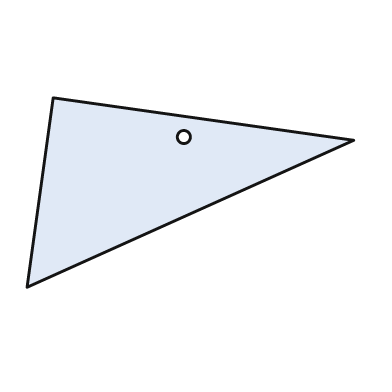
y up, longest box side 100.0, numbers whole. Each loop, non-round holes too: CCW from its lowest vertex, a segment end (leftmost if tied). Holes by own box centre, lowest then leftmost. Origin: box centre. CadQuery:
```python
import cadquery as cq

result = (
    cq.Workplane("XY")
    .moveTo(-50.0, -29.0)
    .lineTo(50.0, 16.0)
    .lineTo(-42.0, 29.0)
    .close()
    .moveTo(-2.0, 17.0)
    .circle(2.0)
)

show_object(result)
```